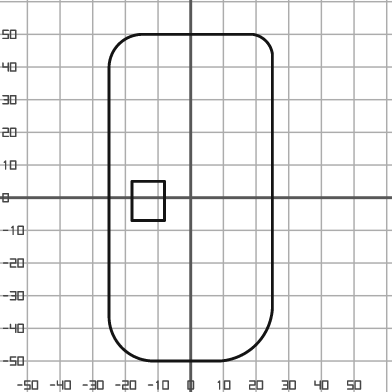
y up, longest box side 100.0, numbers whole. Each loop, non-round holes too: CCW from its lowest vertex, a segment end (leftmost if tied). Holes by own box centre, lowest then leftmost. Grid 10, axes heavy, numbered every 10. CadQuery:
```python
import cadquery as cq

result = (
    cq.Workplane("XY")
    .moveTo(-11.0, -50.0)
    .lineTo(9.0, -50.0)
    .threePointArc((20.0, -45.0), (25.0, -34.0))
    .lineTo(25.0, 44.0)
    .threePointArc((23.0, 48.0), (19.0, 50.0))
    .lineTo(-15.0, 50.0)
    .threePointArc((-22.0, 47.0), (-25.0, 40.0))
    .lineTo(-25.0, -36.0)
    .threePointArc((-21.0, -46.0), (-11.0, -50.0))
    .close()
    .moveTo(-18.0, -7.0)
    .lineTo(-8.0, -7.0)
    .lineTo(-8.0, 5.0)
    .lineTo(-18.0, 5.0)
    .close()
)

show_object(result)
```